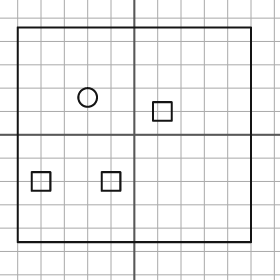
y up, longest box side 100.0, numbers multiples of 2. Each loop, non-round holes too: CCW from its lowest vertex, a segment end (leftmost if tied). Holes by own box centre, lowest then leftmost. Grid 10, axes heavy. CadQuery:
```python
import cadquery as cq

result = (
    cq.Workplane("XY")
    .moveTo(-50.0, -46.0)
    .lineTo(50.0, -46.0)
    .lineTo(50.0, 46.0)
    .lineTo(-50.0, 46.0)
    .close()
    .moveTo(-44.0, -24.0)
    .lineTo(-36.0, -24.0)
    .lineTo(-36.0, -16.0)
    .lineTo(-44.0, -16.0)
    .close()
    .moveTo(-14.0, -24.0)
    .lineTo(-6.0, -24.0)
    .lineTo(-6.0, -16.0)
    .lineTo(-14.0, -16.0)
    .close()
    .moveTo(8.0, 6.0)
    .lineTo(16.0, 6.0)
    .lineTo(16.0, 14.0)
    .lineTo(8.0, 14.0)
    .close()
    .moveTo(-20.0, 16.0)
    .circle(4.0)
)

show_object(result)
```